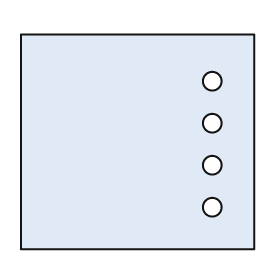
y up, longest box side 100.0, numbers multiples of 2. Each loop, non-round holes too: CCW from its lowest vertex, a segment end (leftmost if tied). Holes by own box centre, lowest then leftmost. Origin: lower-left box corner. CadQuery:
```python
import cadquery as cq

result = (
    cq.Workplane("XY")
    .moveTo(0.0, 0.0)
    .lineTo(100.0, 0.0)
    .lineTo(100.0, 92.0)
    .lineTo(0.0, 92.0)
    .close()
    .moveTo(82.0, 18.0)
    .circle(4.0)
    .moveTo(82.0, 36.0)
    .circle(4.0)
    .moveTo(82.0, 54.0)
    .circle(4.0)
    .moveTo(82.0, 72.0)
    .circle(4.0)
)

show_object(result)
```